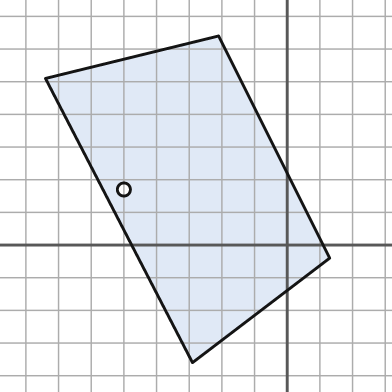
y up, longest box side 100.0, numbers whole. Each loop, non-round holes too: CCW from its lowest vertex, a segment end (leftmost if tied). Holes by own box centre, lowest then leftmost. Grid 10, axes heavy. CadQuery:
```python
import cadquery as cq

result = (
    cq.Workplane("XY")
    .moveTo(-29.0, -36.0)
    .lineTo(13.0, -4.0)
    .lineTo(-21.0, 64.0)
    .lineTo(-74.0, 51.0)
    .close()
    .moveTo(-50.0, 17.0)
    .circle(2.0)
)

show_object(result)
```